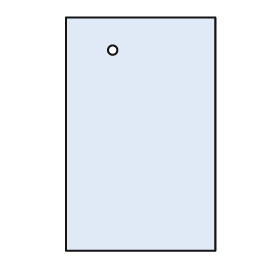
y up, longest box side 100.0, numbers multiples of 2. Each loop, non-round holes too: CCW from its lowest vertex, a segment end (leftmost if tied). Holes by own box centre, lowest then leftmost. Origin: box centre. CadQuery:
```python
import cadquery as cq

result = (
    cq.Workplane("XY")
    .moveTo(-32.0, -50.0)
    .lineTo(32.0, -50.0)
    .lineTo(32.0, 50.0)
    .lineTo(-32.0, 50.0)
    .close()
    .moveTo(-12.0, 36.0)
    .circle(2.0)
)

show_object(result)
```